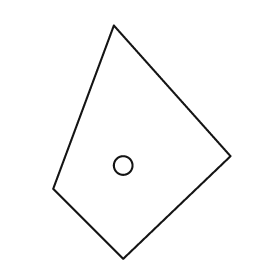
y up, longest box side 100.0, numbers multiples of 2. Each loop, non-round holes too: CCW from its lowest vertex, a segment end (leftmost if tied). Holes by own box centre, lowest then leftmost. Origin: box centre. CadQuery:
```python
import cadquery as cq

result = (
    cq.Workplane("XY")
    .moveTo(-8.0, -50.0)
    .lineTo(38.0, -6.0)
    .lineTo(-12.0, 50.0)
    .lineTo(-38.0, -20.0)
    .close()
    .moveTo(-8.0, -10.0)
    .circle(4.0)
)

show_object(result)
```